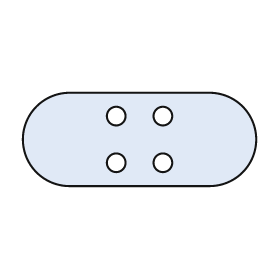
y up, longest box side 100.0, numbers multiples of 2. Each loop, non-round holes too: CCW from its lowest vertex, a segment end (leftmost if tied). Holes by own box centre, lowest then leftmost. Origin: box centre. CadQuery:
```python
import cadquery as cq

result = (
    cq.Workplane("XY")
    .moveTo(-30.0, -20.0)
    .lineTo(30.0, -20.0)
    .threePointArc((50.0, 0.0), (30.0, 20.0))
    .lineTo(-30.0, 20.0)
    .threePointArc((-50.0, 0.0), (-30.0, -20.0))
    .close()
    .moveTo(-10.0, -10.0)
    .circle(4.0)
    .moveTo(10.0, -10.0)
    .circle(4.0)
    .moveTo(-10.0, 10.0)
    .circle(4.0)
    .moveTo(10.0, 10.0)
    .circle(4.0)
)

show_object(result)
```